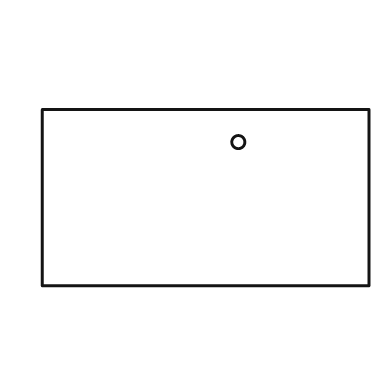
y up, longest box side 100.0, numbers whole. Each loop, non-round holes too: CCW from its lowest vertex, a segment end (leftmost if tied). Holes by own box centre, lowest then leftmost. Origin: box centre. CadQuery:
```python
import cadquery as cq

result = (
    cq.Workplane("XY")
    .moveTo(-50.0, -27.0)
    .lineTo(50.0, -27.0)
    .lineTo(50.0, 27.0)
    .lineTo(-50.0, 27.0)
    .close()
    .moveTo(10.0, 17.0)
    .circle(2.0)
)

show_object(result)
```